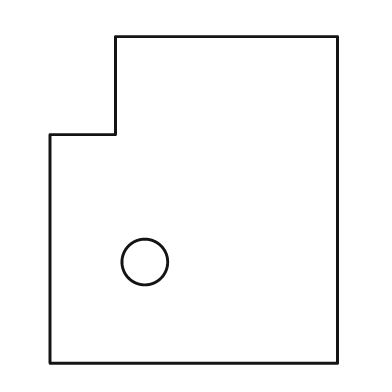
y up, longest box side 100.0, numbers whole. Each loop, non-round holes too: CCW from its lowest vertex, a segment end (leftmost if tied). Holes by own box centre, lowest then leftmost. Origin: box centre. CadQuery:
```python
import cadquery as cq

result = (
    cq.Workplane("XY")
    .moveTo(-44.0, -50.0)
    .lineTo(44.0, -50.0)
    .lineTo(44.0, 50.0)
    .lineTo(-24.0, 50.0)
    .lineTo(-24.0, 20.0)
    .lineTo(-44.0, 20.0)
    .close()
    .moveTo(-15.0, -19.0)
    .circle(7.0)
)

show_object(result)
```